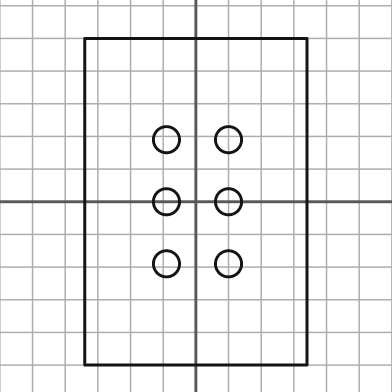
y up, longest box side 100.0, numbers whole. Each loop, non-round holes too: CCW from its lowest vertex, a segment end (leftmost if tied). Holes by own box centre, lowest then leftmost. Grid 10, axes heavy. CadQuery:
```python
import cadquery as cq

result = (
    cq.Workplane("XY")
    .moveTo(-34.0, -50.0)
    .lineTo(34.0, -50.0)
    .lineTo(34.0, 50.0)
    .lineTo(-34.0, 50.0)
    .close()
    .moveTo(-9.0, -19.0)
    .circle(4.0)
    .moveTo(10.0, -19.0)
    .circle(4.0)
    .moveTo(-9.0, 0.0)
    .circle(4.0)
    .moveTo(10.0, 0.0)
    .circle(4.0)
    .moveTo(-9.0, 19.0)
    .circle(4.0)
    .moveTo(10.0, 19.0)
    .circle(4.0)
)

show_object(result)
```